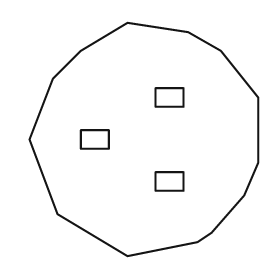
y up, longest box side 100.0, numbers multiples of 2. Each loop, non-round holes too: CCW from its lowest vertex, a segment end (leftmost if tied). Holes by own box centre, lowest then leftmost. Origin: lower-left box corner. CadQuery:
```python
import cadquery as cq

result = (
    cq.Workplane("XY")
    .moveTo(42.0, 0.0)
    .lineTo(72.0, 6.0)
    .lineTo(78.0, 10.0)
    .lineTo(92.0, 26.0)
    .lineTo(98.0, 40.0)
    .lineTo(98.0, 68.0)
    .lineTo(82.0, 88.0)
    .lineTo(68.0, 96.0)
    .lineTo(42.0, 100.0)
    .lineTo(22.0, 88.0)
    .lineTo(10.0, 76.0)
    .lineTo(0.0, 50.0)
    .lineTo(12.0, 18.0)
    .close()
    .moveTo(54.0, 28.0)
    .lineTo(66.0, 28.0)
    .lineTo(66.0, 36.0)
    .lineTo(54.0, 36.0)
    .close()
    .moveTo(22.0, 46.0)
    .lineTo(34.0, 46.0)
    .lineTo(34.0, 54.0)
    .lineTo(22.0, 54.0)
    .close()
    .moveTo(54.0, 64.0)
    .lineTo(66.0, 64.0)
    .lineTo(66.0, 72.0)
    .lineTo(54.0, 72.0)
    .close()
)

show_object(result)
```